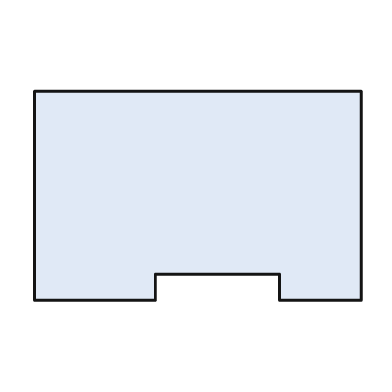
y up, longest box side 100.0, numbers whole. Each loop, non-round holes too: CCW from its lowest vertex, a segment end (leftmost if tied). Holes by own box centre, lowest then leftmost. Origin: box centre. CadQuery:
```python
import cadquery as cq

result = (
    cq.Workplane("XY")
    .moveTo(-50.0, -32.0)
    .lineTo(-13.0, -32.0)
    .lineTo(-13.0, -24.0)
    .lineTo(25.0, -24.0)
    .lineTo(25.0, -32.0)
    .lineTo(50.0, -32.0)
    .lineTo(50.0, 32.0)
    .lineTo(-50.0, 32.0)
    .close()
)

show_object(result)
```